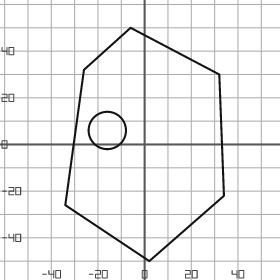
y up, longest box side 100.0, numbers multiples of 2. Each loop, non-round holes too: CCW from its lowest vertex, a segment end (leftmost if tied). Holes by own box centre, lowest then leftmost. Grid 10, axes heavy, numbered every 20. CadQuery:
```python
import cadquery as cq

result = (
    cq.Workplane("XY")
    .moveTo(2.0, -50.0)
    .lineTo(34.0, -22.0)
    .lineTo(32.0, 30.0)
    .lineTo(-6.0, 50.0)
    .lineTo(-26.0, 32.0)
    .lineTo(-34.0, -26.0)
    .close()
    .moveTo(-16.0, 6.0)
    .circle(8.0)
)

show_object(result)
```